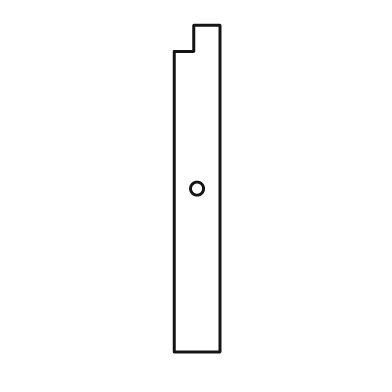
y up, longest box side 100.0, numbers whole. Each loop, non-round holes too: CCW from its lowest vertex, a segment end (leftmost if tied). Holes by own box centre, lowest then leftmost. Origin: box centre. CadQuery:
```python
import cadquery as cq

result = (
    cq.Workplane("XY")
    .moveTo(-7.0, -50.0)
    .lineTo(7.0, -50.0)
    .lineTo(7.0, 50.0)
    .lineTo(-1.0, 50.0)
    .lineTo(-1.0, 42.0)
    .lineTo(-7.0, 42.0)
    .close()
    .moveTo(0.0, 0.0)
    .circle(2.0)
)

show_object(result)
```